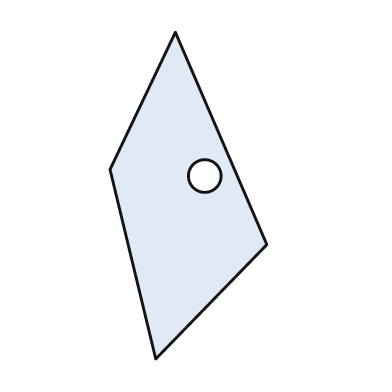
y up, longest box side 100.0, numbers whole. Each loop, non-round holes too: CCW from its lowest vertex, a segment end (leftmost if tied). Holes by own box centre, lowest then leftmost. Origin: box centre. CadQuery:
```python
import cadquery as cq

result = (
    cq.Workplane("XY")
    .moveTo(-10.0, -50.0)
    .lineTo(24.0, -15.0)
    .lineTo(-4.0, 50.0)
    .lineTo(-24.0, 8.0)
    .close()
    .moveTo(5.0, 6.0)
    .circle(5.0)
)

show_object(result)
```